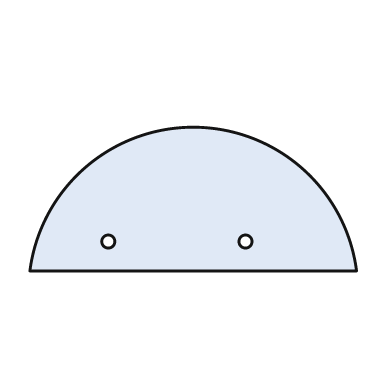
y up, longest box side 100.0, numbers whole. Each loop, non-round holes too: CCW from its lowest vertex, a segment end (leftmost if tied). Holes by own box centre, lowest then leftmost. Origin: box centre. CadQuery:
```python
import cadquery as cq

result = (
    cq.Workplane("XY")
    .moveTo(-50.0, -22.0)
    .lineTo(50.0, -22.0)
    .threePointArc((0.0, 22.0), (-50.0, -22.0))
    .close()
    .moveTo(-26.0, -13.0)
    .circle(2.0)
    .moveTo(16.0, -13.0)
    .circle(2.0)
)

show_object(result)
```